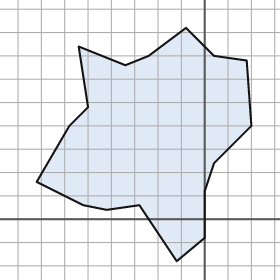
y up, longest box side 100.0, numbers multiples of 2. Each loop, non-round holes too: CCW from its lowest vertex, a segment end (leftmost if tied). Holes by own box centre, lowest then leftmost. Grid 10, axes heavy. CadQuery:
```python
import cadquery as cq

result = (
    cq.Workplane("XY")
    .moveTo(-12.0, -18.0)
    .lineTo(0.0, -8.0)
    .lineTo(0.0, 12.0)
    .lineTo(4.0, 24.0)
    .lineTo(20.0, 40.0)
    .lineTo(18.0, 68.0)
    .lineTo(4.0, 70.0)
    .lineTo(-8.0, 82.0)
    .lineTo(-24.0, 70.0)
    .lineTo(-34.0, 66.0)
    .lineTo(-54.0, 74.0)
    .lineTo(-50.0, 48.0)
    .lineTo(-58.0, 40.0)
    .lineTo(-72.0, 16.0)
    .lineTo(-52.0, 6.0)
    .lineTo(-42.0, 4.0)
    .lineTo(-28.0, 6.0)
    .close()
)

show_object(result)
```